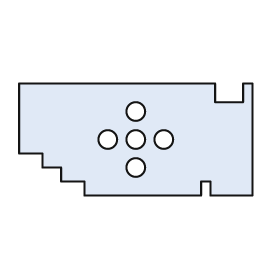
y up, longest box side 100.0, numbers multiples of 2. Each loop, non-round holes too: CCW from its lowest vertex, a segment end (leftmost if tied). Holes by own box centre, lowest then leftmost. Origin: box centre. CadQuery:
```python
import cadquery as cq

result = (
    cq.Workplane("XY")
    .moveTo(-22.0, -24.0)
    .lineTo(28.0, -24.0)
    .lineTo(28.0, -18.0)
    .lineTo(32.0, -18.0)
    .lineTo(32.0, -24.0)
    .lineTo(50.0, -24.0)
    .lineTo(50.0, 24.0)
    .lineTo(46.0, 24.0)
    .lineTo(46.0, 16.0)
    .lineTo(34.0, 16.0)
    .lineTo(34.0, 24.0)
    .lineTo(-50.0, 24.0)
    .lineTo(-50.0, -6.0)
    .lineTo(-40.0, -6.0)
    .lineTo(-40.0, -12.0)
    .lineTo(-32.0, -12.0)
    .lineTo(-32.0, -18.0)
    .lineTo(-22.0, -18.0)
    .close()
    .moveTo(0.0, -12.0)
    .circle(4.0)
    .moveTo(-12.0, 0.0)
    .circle(4.0)
    .moveTo(0.0, 0.0)
    .circle(4.0)
    .moveTo(12.0, 0.0)
    .circle(4.0)
    .moveTo(0.0, 12.0)
    .circle(4.0)
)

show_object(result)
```